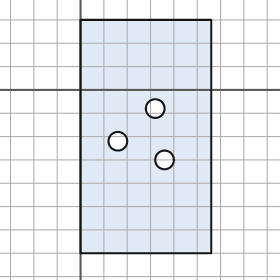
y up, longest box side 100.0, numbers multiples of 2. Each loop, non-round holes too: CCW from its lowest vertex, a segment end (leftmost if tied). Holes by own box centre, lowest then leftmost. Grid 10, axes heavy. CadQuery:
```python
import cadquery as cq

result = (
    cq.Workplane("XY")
    .moveTo(0.0, -70.0)
    .lineTo(56.0, -70.0)
    .lineTo(56.0, 30.0)
    .lineTo(0.0, 30.0)
    .close()
    .moveTo(36.0, -30.0)
    .circle(4.0)
    .moveTo(16.0, -22.0)
    .circle(4.0)
    .moveTo(32.0, -8.0)
    .circle(4.0)
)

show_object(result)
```